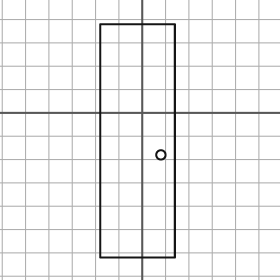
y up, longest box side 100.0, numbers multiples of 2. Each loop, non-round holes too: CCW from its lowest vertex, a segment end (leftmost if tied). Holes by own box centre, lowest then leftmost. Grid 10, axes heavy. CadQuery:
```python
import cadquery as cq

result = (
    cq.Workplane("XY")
    .moveTo(-18.0, -62.0)
    .lineTo(14.0, -62.0)
    .lineTo(14.0, 38.0)
    .lineTo(-18.0, 38.0)
    .close()
    .moveTo(8.0, -18.0)
    .circle(2.0)
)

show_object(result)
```